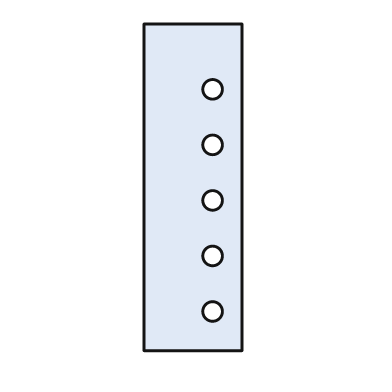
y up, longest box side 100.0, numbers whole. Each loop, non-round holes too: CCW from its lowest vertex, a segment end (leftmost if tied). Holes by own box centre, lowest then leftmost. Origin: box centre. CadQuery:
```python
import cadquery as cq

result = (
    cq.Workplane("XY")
    .moveTo(-15.0, -50.0)
    .lineTo(15.0, -50.0)
    .lineTo(15.0, 50.0)
    .lineTo(-15.0, 50.0)
    .close()
    .moveTo(6.0, -38.0)
    .circle(3.0)
    .moveTo(6.0, -21.0)
    .circle(3.0)
    .moveTo(6.0, -4.0)
    .circle(3.0)
    .moveTo(6.0, 13.0)
    .circle(3.0)
    .moveTo(6.0, 30.0)
    .circle(3.0)
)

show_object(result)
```